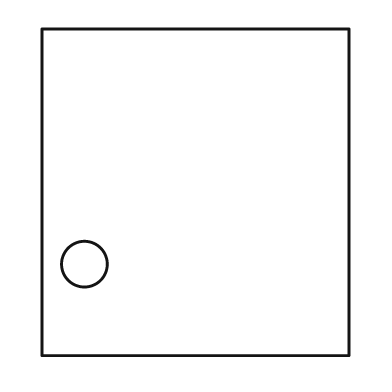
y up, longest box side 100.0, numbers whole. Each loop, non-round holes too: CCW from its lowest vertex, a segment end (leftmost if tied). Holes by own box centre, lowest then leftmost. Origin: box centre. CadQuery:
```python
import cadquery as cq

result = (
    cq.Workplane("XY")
    .moveTo(-47.0, -50.0)
    .lineTo(47.0, -50.0)
    .lineTo(47.0, 50.0)
    .lineTo(-47.0, 50.0)
    .close()
    .moveTo(-34.0, -22.0)
    .circle(7.0)
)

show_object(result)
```